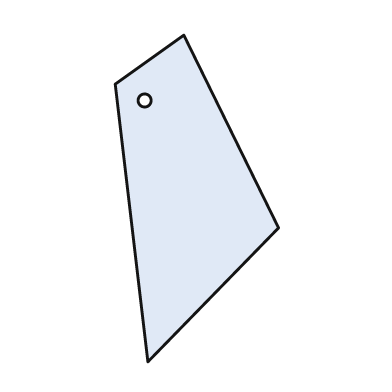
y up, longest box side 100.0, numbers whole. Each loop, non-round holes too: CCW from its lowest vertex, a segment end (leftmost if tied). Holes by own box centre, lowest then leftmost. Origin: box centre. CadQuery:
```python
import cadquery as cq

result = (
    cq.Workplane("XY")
    .moveTo(-15.0, -50.0)
    .lineTo(25.0, -9.0)
    .lineTo(-4.0, 50.0)
    .lineTo(-25.0, 35.0)
    .close()
    .moveTo(-16.0, 30.0)
    .circle(2.0)
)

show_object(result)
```